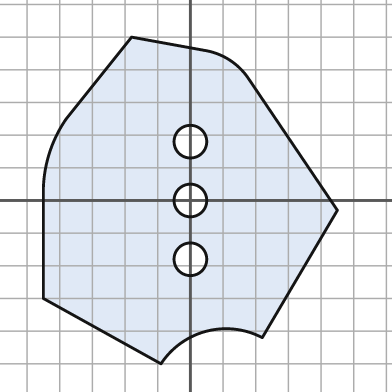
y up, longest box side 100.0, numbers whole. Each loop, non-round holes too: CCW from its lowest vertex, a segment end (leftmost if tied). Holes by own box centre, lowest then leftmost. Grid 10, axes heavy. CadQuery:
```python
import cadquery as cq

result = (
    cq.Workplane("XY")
    .moveTo(-9.0, -50.0)
    .threePointArc((5.0, -40.0), (22.0, -42.0))
    .lineTo(45.0, -3.0)
    .lineTo(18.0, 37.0)
    .threePointArc((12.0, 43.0), (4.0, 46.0))
    .lineTo(-18.0, 50.0)
    .lineTo(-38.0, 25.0)
    .threePointArc((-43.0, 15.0), (-45.0, 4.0))
    .lineTo(-45.0, -30.0)
    .close()
    .moveTo(0.0, -18.0)
    .circle(5.0)
    .moveTo(0.0, 0.0)
    .circle(5.0)
    .moveTo(0.0, 18.0)
    .circle(5.0)
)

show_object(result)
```